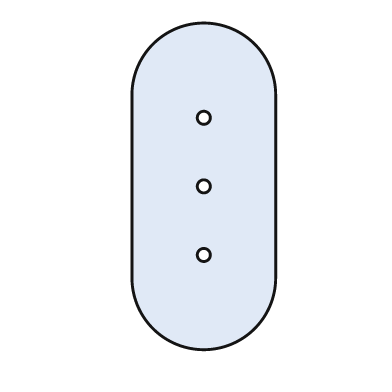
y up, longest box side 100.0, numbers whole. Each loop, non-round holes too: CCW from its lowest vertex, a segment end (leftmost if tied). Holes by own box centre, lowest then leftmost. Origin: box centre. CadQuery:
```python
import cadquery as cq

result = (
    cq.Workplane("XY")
    .moveTo(-22.0, -28.0)
    .threePointArc((0.0, -50.0), (22.0, -28.0))
    .lineTo(22.0, 28.0)
    .threePointArc((0.0, 50.0), (-22.0, 28.0))
    .close()
    .moveTo(0.0, -21.0)
    .circle(2.0)
    .moveTo(0.0, 0.0)
    .circle(2.0)
    .moveTo(0.0, 21.0)
    .circle(2.0)
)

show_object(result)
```